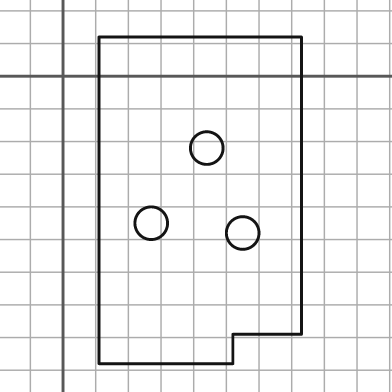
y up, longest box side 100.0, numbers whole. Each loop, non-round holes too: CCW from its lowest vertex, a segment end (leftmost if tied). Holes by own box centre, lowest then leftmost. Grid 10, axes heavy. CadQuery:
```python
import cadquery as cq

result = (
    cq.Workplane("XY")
    .moveTo(11.0, -88.0)
    .lineTo(52.0, -88.0)
    .lineTo(52.0, -79.0)
    .lineTo(73.0, -79.0)
    .lineTo(73.0, 12.0)
    .lineTo(11.0, 12.0)
    .close()
    .moveTo(55.0, -48.0)
    .circle(5.0)
    .moveTo(27.0, -45.0)
    .circle(5.0)
    .moveTo(44.0, -22.0)
    .circle(5.0)
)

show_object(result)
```